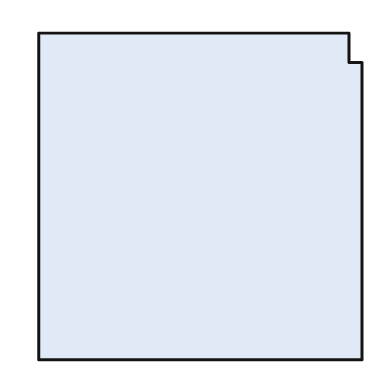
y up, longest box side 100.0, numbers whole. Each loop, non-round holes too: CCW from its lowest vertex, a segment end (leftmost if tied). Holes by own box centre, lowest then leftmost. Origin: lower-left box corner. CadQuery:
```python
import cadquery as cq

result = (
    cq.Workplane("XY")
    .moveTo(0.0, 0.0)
    .lineTo(99.0, 0.0)
    .lineTo(99.0, 91.0)
    .lineTo(95.0, 91.0)
    .lineTo(95.0, 100.0)
    .lineTo(0.0, 100.0)
    .close()
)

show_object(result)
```